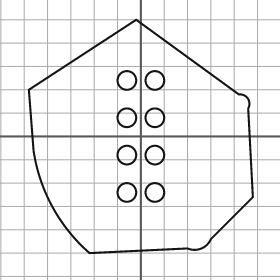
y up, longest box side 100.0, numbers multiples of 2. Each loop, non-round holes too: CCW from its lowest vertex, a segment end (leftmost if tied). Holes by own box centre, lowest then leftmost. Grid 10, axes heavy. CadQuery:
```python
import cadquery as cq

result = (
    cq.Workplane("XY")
    .moveTo(-22.0, -50.0)
    .lineTo(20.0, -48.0)
    .threePointArc((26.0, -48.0), (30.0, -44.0))
    .lineTo(48.0, -26.0)
    .lineTo(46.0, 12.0)
    .threePointArc((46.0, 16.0), (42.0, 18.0))
    .lineTo(-2.0, 50.0)
    .lineTo(-48.0, 20.0)
    .lineTo(-46.0, -6.0)
    .threePointArc((-38.0, -30.0), (-22.0, -50.0))
    .close()
    .moveTo(-6.0, -24.0)
    .circle(4.0)
    .moveTo(6.0, -24.0)
    .circle(4.0)
    .moveTo(-6.0, -8.0)
    .circle(4.0)
    .moveTo(6.0, -8.0)
    .circle(4.0)
    .moveTo(-6.0, 8.0)
    .circle(4.0)
    .moveTo(6.0, 8.0)
    .circle(4.0)
    .moveTo(-6.0, 24.0)
    .circle(4.0)
    .moveTo(6.0, 24.0)
    .circle(4.0)
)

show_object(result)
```